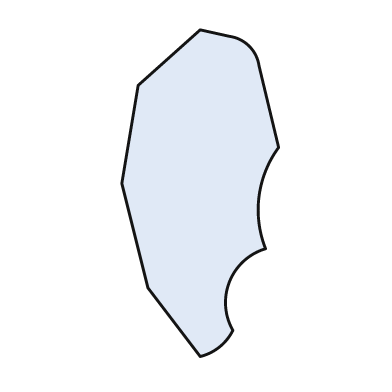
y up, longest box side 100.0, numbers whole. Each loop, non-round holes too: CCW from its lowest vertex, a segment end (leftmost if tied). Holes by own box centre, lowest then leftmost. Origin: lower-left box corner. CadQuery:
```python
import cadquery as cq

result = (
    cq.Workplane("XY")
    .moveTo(24.0, 0.0)
    .threePointArc((30.0, 3.0), (34.0, 8.0))
    .threePointArc((33.0, 23.0), (44.0, 33.0))
    .threePointArc((42.0, 49.0), (48.0, 64.0))
    .lineTo(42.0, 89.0)
    .threePointArc((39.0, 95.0), (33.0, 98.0))
    .lineTo(24.0, 100.0)
    .lineTo(5.0, 83.0)
    .lineTo(0.0, 53.0)
    .lineTo(8.0, 21.0)
    .close()
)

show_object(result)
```